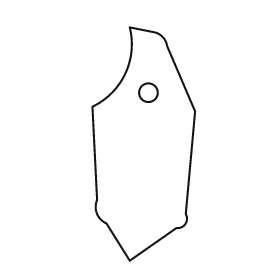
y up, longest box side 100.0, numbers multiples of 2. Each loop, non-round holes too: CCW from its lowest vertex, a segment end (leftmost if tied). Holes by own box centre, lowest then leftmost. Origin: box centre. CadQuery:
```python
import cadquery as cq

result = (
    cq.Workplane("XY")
    .moveTo(-6.0, -50.0)
    .lineTo(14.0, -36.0)
    .threePointArc((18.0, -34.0), (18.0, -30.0))
    .lineTo(22.0, 14.0)
    .lineTo(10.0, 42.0)
    .threePointArc((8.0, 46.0), (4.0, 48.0))
    .lineTo(-6.0, 50.0)
    .threePointArc((-8.0, 30.0), (-22.0, 16.0))
    .lineTo(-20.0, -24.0)
    .threePointArc((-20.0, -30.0), (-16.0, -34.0))
    .close()
    .moveTo(2.0, 22.0)
    .circle(4.0)
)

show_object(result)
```